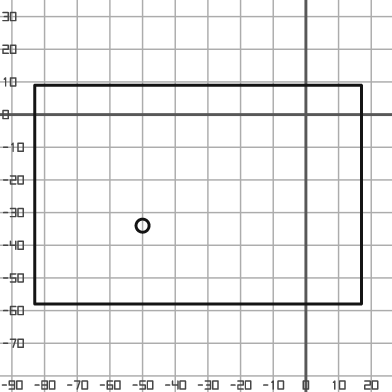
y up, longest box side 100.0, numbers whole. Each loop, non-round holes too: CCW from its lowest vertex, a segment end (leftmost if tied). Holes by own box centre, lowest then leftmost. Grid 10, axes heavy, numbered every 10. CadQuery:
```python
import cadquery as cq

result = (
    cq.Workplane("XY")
    .moveTo(-83.0, -58.0)
    .lineTo(17.0, -58.0)
    .lineTo(17.0, 9.0)
    .lineTo(-83.0, 9.0)
    .close()
    .moveTo(-50.0, -34.0)
    .circle(2.0)
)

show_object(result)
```